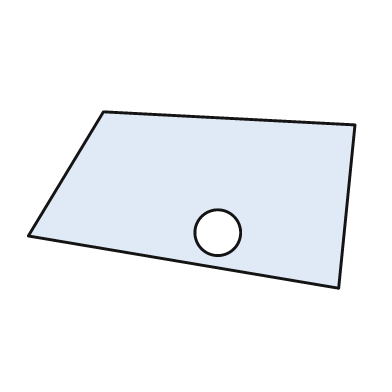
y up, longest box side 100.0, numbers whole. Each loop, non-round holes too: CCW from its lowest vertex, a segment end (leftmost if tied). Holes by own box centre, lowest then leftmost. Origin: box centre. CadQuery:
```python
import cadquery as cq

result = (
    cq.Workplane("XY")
    .moveTo(45.0, -27.0)
    .lineTo(50.0, 23.0)
    .lineTo(-27.0, 27.0)
    .lineTo(-50.0, -11.0)
    .close()
    .moveTo(8.0, -10.0)
    .circle(7.0)
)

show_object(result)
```